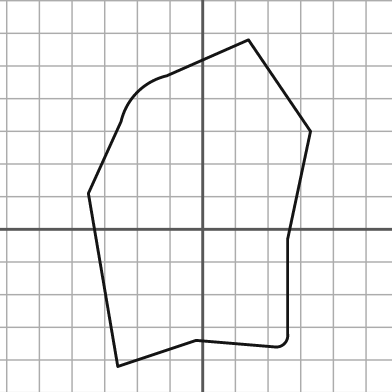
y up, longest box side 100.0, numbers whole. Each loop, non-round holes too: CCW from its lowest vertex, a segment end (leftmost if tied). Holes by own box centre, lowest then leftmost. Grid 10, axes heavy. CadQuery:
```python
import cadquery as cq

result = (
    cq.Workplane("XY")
    .moveTo(-26.0, -42.0)
    .lineTo(-2.0, -34.0)
    .lineTo(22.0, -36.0)
    .threePointArc((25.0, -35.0), (26.0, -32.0))
    .lineTo(26.0, -3.0)
    .lineTo(33.0, 30.0)
    .lineTo(14.0, 58.0)
    .lineTo(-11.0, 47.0)
    .threePointArc((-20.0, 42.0), (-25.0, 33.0))
    .lineTo(-35.0, 11.0)
    .close()
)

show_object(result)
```